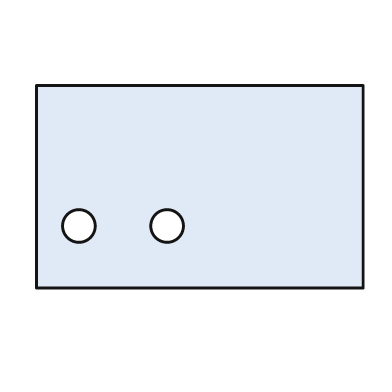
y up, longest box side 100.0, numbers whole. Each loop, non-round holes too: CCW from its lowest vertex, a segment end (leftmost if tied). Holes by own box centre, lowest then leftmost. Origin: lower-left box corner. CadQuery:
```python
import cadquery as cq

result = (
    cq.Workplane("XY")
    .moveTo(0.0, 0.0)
    .lineTo(100.0, 0.0)
    .lineTo(100.0, 62.0)
    .lineTo(0.0, 62.0)
    .close()
    .moveTo(13.0, 19.0)
    .circle(5.0)
    .moveTo(40.0, 19.0)
    .circle(5.0)
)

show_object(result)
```